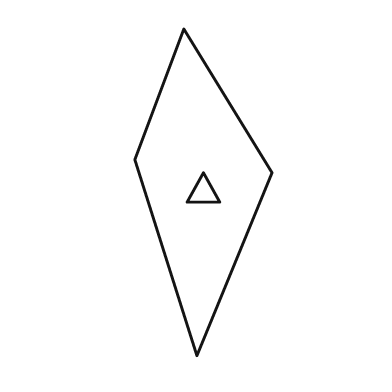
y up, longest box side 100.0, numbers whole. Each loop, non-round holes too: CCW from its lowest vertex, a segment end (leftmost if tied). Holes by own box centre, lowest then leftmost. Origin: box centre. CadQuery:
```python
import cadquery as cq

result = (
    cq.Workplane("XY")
    .moveTo(-2.0, -50.0)
    .lineTo(21.0, 6.0)
    .lineTo(-6.0, 50.0)
    .lineTo(-21.0, 10.0)
    .close()
    .moveTo(-5.0, -3.0)
    .lineTo(5.0, -3.0)
    .lineTo(0.0, 6.0)
    .close()
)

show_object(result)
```